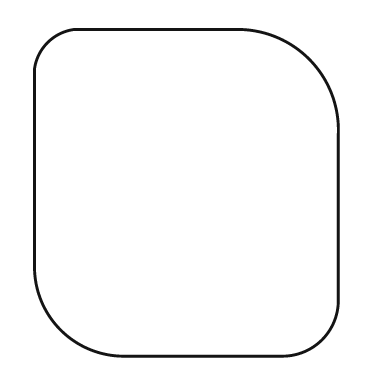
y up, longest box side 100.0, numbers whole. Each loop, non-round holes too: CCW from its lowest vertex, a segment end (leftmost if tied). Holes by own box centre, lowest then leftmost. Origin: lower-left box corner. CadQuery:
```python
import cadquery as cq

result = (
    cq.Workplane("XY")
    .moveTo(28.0, 0.0)
    .lineTo(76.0, 0.0)
    .threePointArc((88.0, 5.0), (93.0, 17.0))
    .lineTo(93.0, 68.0)
    .threePointArc((84.0, 91.0), (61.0, 100.0))
    .lineTo(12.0, 100.0)
    .threePointArc((4.0, 96.0), (0.0, 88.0))
    .lineTo(0.0, 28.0)
    .threePointArc((8.0, 8.0), (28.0, 0.0))
    .close()
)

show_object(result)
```